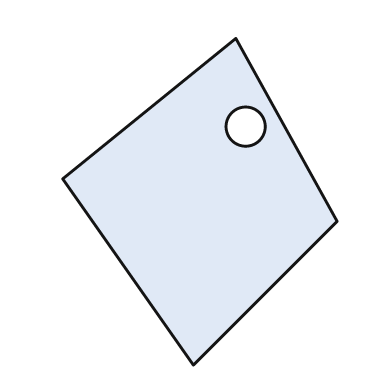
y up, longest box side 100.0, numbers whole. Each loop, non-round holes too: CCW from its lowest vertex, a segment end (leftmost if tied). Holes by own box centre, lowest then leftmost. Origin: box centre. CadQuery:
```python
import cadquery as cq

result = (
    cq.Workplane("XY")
    .moveTo(-2.0, -50.0)
    .lineTo(42.0, -6.0)
    .lineTo(11.0, 50.0)
    .lineTo(-42.0, 7.0)
    .close()
    .moveTo(14.0, 23.0)
    .circle(6.0)
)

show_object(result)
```